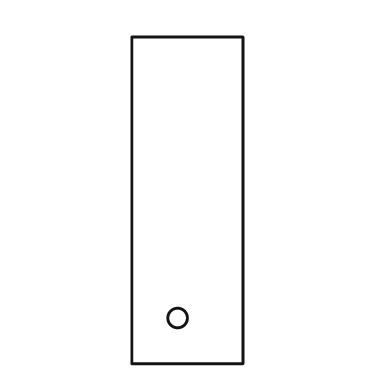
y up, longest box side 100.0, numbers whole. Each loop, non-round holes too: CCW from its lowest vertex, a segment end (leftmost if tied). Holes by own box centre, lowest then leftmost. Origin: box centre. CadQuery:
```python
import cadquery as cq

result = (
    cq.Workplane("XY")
    .moveTo(-17.0, -50.0)
    .lineTo(17.0, -50.0)
    .lineTo(17.0, 50.0)
    .lineTo(-17.0, 50.0)
    .close()
    .moveTo(-3.0, -36.0)
    .circle(3.0)
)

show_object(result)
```